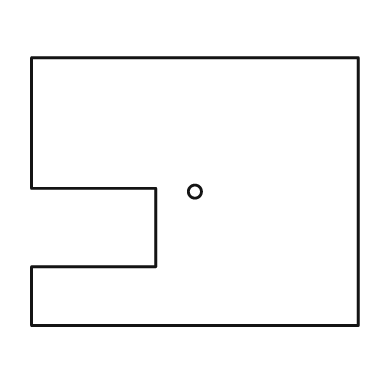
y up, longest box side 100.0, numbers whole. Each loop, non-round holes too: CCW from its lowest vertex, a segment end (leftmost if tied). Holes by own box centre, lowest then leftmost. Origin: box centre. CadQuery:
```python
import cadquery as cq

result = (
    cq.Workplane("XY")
    .moveTo(-50.0, -41.0)
    .lineTo(50.0, -41.0)
    .lineTo(50.0, 41.0)
    .lineTo(-50.0, 41.0)
    .lineTo(-50.0, 1.0)
    .lineTo(-12.0, 1.0)
    .lineTo(-12.0, -23.0)
    .lineTo(-50.0, -23.0)
    .close()
    .moveTo(0.0, 0.0)
    .circle(2.0)
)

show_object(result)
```